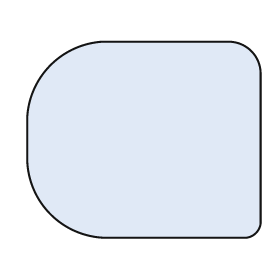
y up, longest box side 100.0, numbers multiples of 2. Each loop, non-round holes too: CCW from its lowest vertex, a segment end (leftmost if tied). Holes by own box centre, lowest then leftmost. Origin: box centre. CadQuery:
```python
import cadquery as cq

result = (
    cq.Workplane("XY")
    .moveTo(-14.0, -42.0)
    .lineTo(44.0, -42.0)
    .threePointArc((48.0, -40.0), (50.0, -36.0))
    .lineTo(50.0, 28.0)
    .threePointArc((46.0, 38.0), (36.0, 42.0))
    .lineTo(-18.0, 42.0)
    .threePointArc((-40.0, 32.0), (-50.0, 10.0))
    .lineTo(-50.0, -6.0)
    .threePointArc((-40.0, -32.0), (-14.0, -42.0))
    .close()
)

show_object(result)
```